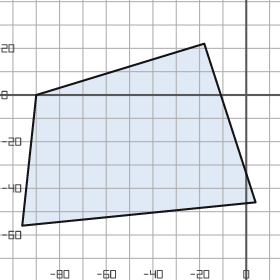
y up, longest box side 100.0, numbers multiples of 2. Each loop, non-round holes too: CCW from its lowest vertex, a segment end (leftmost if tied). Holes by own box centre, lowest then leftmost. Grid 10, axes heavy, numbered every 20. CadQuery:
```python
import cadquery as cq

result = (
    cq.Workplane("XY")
    .moveTo(-96.0, -56.0)
    .lineTo(4.0, -46.0)
    .lineTo(-18.0, 22.0)
    .lineTo(-90.0, 0.0)
    .close()
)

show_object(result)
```